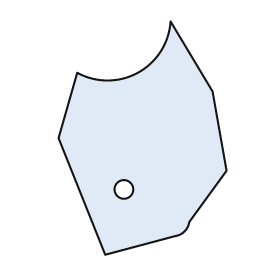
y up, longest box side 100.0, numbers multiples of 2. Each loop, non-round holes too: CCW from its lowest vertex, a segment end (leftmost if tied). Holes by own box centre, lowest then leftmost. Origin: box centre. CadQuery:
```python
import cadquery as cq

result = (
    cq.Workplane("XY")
    .moveTo(-16.0, -50.0)
    .lineTo(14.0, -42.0)
    .threePointArc((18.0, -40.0), (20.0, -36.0))
    .lineTo(36.0, -14.0)
    .lineTo(30.0, 20.0)
    .lineTo(12.0, 50.0)
    .threePointArc((-2.0, 28.0), (-28.0, 28.0))
    .lineTo(-36.0, 0.0)
    .close()
    .moveTo(-8.0, -22.0)
    .circle(4.0)
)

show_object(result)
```